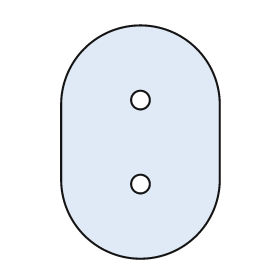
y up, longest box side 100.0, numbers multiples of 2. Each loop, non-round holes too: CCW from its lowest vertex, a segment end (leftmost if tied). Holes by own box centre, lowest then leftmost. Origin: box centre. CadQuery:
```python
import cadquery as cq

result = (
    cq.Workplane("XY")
    .moveTo(-34.0, -16.0)
    .threePointArc((0.0, -50.0), (34.0, -16.0))
    .lineTo(34.0, 16.0)
    .threePointArc((0.0, 50.0), (-34.0, 16.0))
    .close()
    .moveTo(0.0, -18.0)
    .circle(4.0)
    .moveTo(0.0, 18.0)
    .circle(4.0)
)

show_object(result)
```